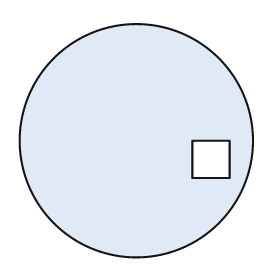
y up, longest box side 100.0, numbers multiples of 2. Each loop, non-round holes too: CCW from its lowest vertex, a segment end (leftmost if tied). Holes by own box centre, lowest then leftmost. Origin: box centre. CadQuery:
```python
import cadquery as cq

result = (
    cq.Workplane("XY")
    .moveTo(0.0, 0.0)
    .circle(50.0)
    .moveTo(24.0, -16.0)
    .lineTo(40.0, -16.0)
    .lineTo(40.0, 0.0)
    .lineTo(24.0, 0.0)
    .close()
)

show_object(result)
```